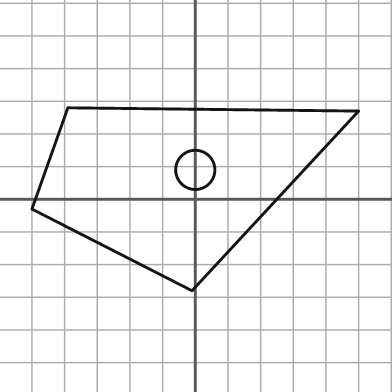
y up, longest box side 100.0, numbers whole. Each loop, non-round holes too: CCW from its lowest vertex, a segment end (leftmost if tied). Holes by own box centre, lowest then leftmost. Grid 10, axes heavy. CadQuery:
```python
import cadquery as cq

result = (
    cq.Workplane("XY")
    .moveTo(-1.0, -28.0)
    .lineTo(50.0, 27.0)
    .lineTo(-39.0, 28.0)
    .lineTo(-50.0, -3.0)
    .close()
    .moveTo(0.0, 9.0)
    .circle(6.0)
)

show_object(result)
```